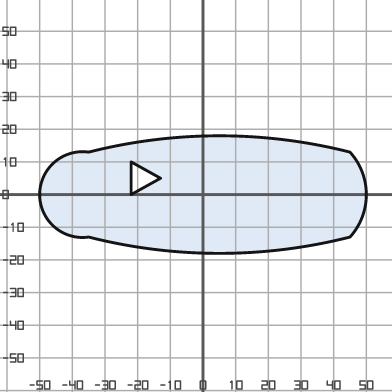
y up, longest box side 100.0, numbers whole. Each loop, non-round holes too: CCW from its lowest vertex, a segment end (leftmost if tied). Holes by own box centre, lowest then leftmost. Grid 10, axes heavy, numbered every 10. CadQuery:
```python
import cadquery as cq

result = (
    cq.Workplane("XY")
    .moveTo(-35.0, -13.0)
    .threePointArc((5.0, -18.0), (45.0, -13.0))
    .threePointArc((50.0, 0.0), (45.0, 13.0))
    .threePointArc((5.0, 18.0), (-35.0, 13.0))
    .threePointArc((-50.0, 0.0), (-35.0, -13.0))
    .close()
    .moveTo(-22.0, 0.0)
    .lineTo(-13.0, 5.0)
    .lineTo(-22.0, 10.0)
    .close()
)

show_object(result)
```